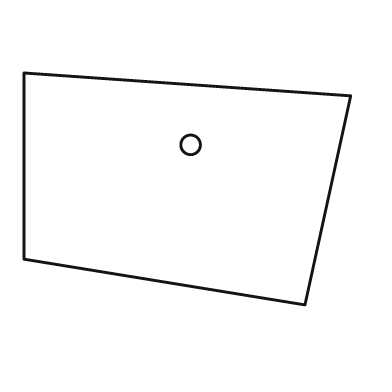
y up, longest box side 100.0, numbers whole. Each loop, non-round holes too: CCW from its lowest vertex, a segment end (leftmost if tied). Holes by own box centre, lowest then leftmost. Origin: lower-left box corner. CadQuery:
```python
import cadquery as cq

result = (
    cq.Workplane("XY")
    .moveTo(86.0, 0.0)
    .lineTo(100.0, 64.0)
    .lineTo(0.0, 71.0)
    .lineTo(0.0, 14.0)
    .close()
    .moveTo(51.0, 49.0)
    .circle(3.0)
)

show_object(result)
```